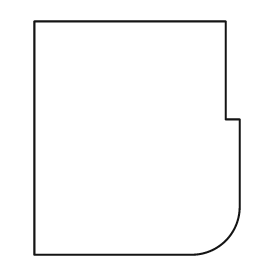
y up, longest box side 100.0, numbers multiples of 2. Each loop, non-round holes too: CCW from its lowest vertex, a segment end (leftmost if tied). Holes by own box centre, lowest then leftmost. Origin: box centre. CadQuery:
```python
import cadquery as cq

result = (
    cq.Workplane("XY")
    .moveTo(-44.0, -50.0)
    .lineTo(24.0, -50.0)
    .threePointArc((38.0, -44.0), (44.0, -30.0))
    .lineTo(44.0, 8.0)
    .lineTo(38.0, 8.0)
    .lineTo(38.0, 50.0)
    .lineTo(-44.0, 50.0)
    .close()
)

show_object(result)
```